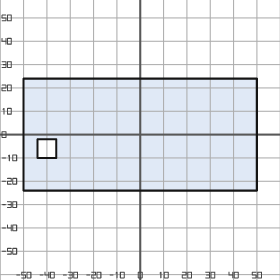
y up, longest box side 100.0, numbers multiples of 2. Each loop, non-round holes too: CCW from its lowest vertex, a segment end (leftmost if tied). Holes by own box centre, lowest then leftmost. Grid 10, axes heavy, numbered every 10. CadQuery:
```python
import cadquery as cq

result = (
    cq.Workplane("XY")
    .moveTo(-50.0, -24.0)
    .lineTo(50.0, -24.0)
    .lineTo(50.0, 24.0)
    .lineTo(-50.0, 24.0)
    .close()
    .moveTo(-44.0, -10.0)
    .lineTo(-36.0, -10.0)
    .lineTo(-36.0, -2.0)
    .lineTo(-44.0, -2.0)
    .close()
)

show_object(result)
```